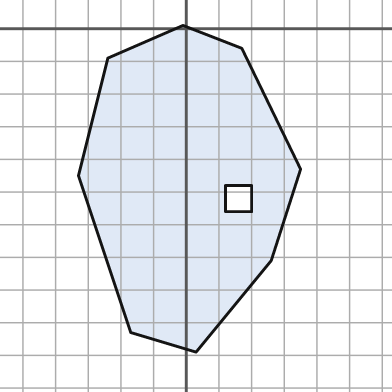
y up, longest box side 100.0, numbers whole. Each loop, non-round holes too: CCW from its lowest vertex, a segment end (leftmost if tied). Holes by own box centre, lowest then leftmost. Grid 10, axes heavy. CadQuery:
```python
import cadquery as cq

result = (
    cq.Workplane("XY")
    .moveTo(3.0, -99.0)
    .lineTo(26.0, -71.0)
    .lineTo(35.0, -43.0)
    .lineTo(17.0, -6.0)
    .lineTo(-1.0, 1.0)
    .lineTo(-24.0, -9.0)
    .lineTo(-33.0, -45.0)
    .lineTo(-17.0, -93.0)
    .close()
    .moveTo(12.0, -56.0)
    .lineTo(20.0, -56.0)
    .lineTo(20.0, -48.0)
    .lineTo(12.0, -48.0)
    .close()
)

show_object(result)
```